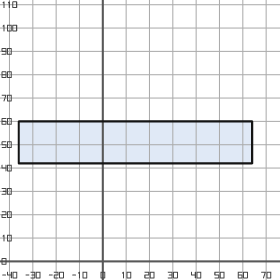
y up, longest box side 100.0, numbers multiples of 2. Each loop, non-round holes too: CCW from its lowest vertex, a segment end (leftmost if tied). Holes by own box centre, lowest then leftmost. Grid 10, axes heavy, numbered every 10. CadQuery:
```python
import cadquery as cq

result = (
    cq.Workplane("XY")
    .moveTo(-36.0, 42.0)
    .lineTo(64.0, 42.0)
    .lineTo(64.0, 60.0)
    .lineTo(-36.0, 60.0)
    .close()
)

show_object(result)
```